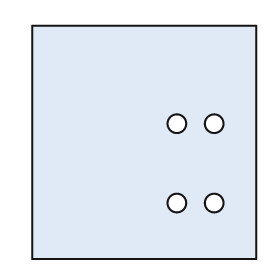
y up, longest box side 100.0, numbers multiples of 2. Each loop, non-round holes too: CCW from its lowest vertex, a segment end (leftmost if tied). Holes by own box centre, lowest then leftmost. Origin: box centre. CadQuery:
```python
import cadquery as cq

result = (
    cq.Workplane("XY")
    .moveTo(-48.0, -50.0)
    .lineTo(48.0, -50.0)
    .lineTo(48.0, 50.0)
    .lineTo(-48.0, 50.0)
    .close()
    .moveTo(14.0, -26.0)
    .circle(4.0)
    .moveTo(30.0, -26.0)
    .circle(4.0)
    .moveTo(14.0, 8.0)
    .circle(4.0)
    .moveTo(30.0, 8.0)
    .circle(4.0)
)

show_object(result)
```